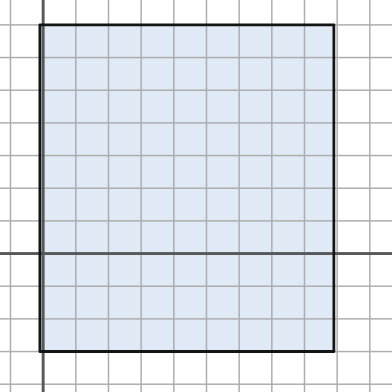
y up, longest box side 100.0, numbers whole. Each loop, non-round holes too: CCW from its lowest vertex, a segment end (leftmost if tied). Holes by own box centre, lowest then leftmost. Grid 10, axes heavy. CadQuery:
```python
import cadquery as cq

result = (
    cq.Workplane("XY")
    .moveTo(-1.0, -30.0)
    .lineTo(89.0, -30.0)
    .lineTo(89.0, 70.0)
    .lineTo(-1.0, 70.0)
    .close()
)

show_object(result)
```